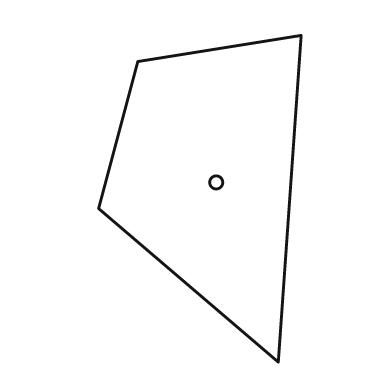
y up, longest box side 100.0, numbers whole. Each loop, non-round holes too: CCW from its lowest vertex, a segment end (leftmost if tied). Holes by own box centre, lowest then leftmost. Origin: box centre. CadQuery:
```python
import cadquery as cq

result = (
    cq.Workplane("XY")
    .moveTo(24.0, -50.0)
    .lineTo(31.0, 50.0)
    .lineTo(-19.0, 42.0)
    .lineTo(-31.0, -3.0)
    .close()
    .moveTo(5.0, 5.0)
    .circle(2.0)
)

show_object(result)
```